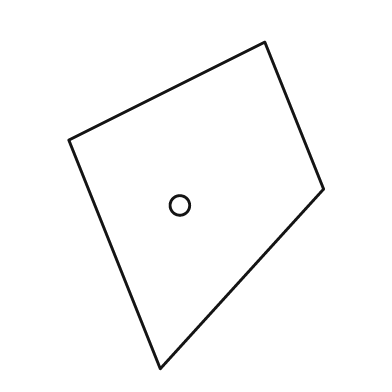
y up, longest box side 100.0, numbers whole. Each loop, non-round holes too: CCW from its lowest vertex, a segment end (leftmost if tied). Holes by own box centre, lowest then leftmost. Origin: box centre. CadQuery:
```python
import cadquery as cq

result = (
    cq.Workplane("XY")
    .moveTo(-11.0, -50.0)
    .lineTo(39.0, 5.0)
    .lineTo(21.0, 50.0)
    .lineTo(-39.0, 20.0)
    .close()
    .moveTo(-5.0, 0.0)
    .circle(3.0)
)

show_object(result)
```